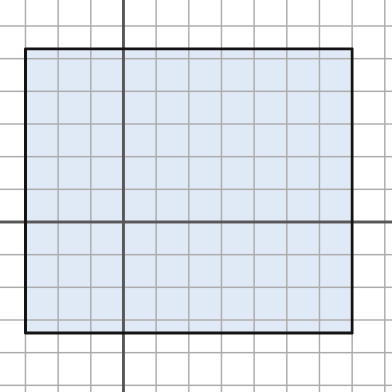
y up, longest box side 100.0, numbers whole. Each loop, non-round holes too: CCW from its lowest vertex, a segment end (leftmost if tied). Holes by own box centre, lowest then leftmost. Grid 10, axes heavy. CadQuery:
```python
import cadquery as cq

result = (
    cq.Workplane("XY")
    .moveTo(-30.0, -34.0)
    .lineTo(70.0, -34.0)
    .lineTo(70.0, 53.0)
    .lineTo(-30.0, 53.0)
    .close()
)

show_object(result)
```